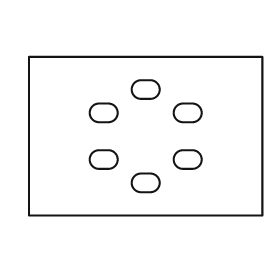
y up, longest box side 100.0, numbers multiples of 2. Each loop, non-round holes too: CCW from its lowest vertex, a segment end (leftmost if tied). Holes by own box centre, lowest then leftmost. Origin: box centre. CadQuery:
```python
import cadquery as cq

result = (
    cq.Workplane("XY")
    .moveTo(-50.0, -34.0)
    .lineTo(50.0, -34.0)
    .lineTo(50.0, 34.0)
    .lineTo(-50.0, 34.0)
    .close()
    .moveTo(-2.0, -24.0)
    .lineTo(2.0, -24.0)
    .threePointArc((6.0, -20.0), (2.0, -16.0))
    .lineTo(-2.0, -16.0)
    .threePointArc((-6.0, -20.0), (-2.0, -24.0))
    .close()
    .moveTo(-20.0, -14.0)
    .lineTo(-16.0, -14.0)
    .threePointArc((-12.0, -10.0), (-16.0, -6.0))
    .lineTo(-20.0, -6.0)
    .threePointArc((-24.0, -10.0), (-20.0, -14.0))
    .close()
    .moveTo(16.0, -14.0)
    .lineTo(20.0, -14.0)
    .threePointArc((24.0, -10.0), (20.0, -6.0))
    .lineTo(16.0, -6.0)
    .threePointArc((12.0, -10.0), (16.0, -14.0))
    .close()
    .moveTo(-20.0, 6.0)
    .lineTo(-16.0, 6.0)
    .threePointArc((-12.0, 10.0), (-16.0, 14.0))
    .lineTo(-20.0, 14.0)
    .threePointArc((-24.0, 10.0), (-20.0, 6.0))
    .close()
    .moveTo(16.0, 6.0)
    .lineTo(20.0, 6.0)
    .threePointArc((24.0, 10.0), (20.0, 14.0))
    .lineTo(16.0, 14.0)
    .threePointArc((12.0, 10.0), (16.0, 6.0))
    .close()
    .moveTo(-2.0, 16.0)
    .lineTo(2.0, 16.0)
    .threePointArc((6.0, 20.0), (2.0, 24.0))
    .lineTo(-2.0, 24.0)
    .threePointArc((-6.0, 20.0), (-2.0, 16.0))
    .close()
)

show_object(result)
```